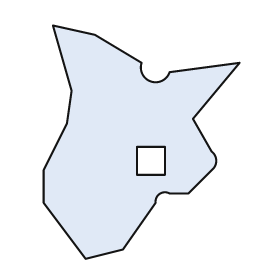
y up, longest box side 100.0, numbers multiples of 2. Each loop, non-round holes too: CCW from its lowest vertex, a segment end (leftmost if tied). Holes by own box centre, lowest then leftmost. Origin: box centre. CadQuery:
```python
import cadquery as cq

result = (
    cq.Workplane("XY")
    .moveTo(-24.0, -50.0)
    .lineTo(-8.0, -46.0)
    .lineTo(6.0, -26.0)
    .threePointArc((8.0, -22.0), (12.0, -22.0))
    .lineTo(20.0, -22.0)
    .lineTo(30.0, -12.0)
    .threePointArc((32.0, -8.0), (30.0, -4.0))
    .lineTo(22.0, 10.0)
    .lineTo(42.0, 34.0)
    .lineTo(12.0, 30.0)
    .threePointArc((4.0, 26.0), (0.0, 34.0))
    .lineTo(-20.0, 46.0)
    .lineTo(-38.0, 50.0)
    .lineTo(-30.0, 22.0)
    .lineTo(-32.0, 8.0)
    .lineTo(-42.0, -12.0)
    .lineTo(-42.0, -26.0)
    .close()
    .moveTo(-2.0, -14.0)
    .lineTo(10.0, -14.0)
    .lineTo(10.0, -2.0)
    .lineTo(-2.0, -2.0)
    .close()
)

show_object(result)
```